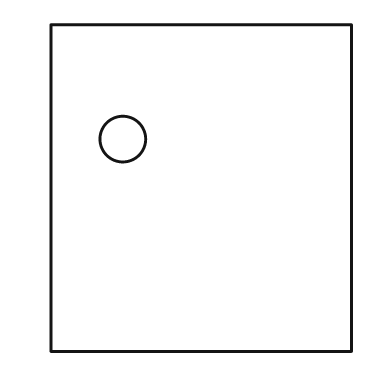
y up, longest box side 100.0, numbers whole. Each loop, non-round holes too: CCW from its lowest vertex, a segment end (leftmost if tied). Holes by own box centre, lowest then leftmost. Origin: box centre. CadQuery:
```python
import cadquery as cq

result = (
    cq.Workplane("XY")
    .moveTo(-46.0, -50.0)
    .lineTo(46.0, -50.0)
    .lineTo(46.0, 50.0)
    .lineTo(-46.0, 50.0)
    .close()
    .moveTo(-24.0, 15.0)
    .circle(7.0)
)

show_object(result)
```